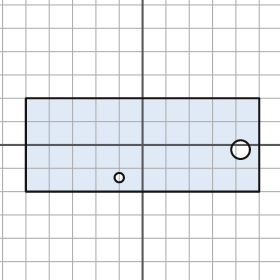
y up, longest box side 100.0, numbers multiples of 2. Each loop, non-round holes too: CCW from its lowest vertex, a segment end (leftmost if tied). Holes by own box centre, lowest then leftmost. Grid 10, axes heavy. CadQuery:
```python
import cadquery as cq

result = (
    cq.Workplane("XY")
    .moveTo(-50.0, -20.0)
    .lineTo(50.0, -20.0)
    .lineTo(50.0, 20.0)
    .lineTo(-50.0, 20.0)
    .close()
    .moveTo(-10.0, -14.0)
    .circle(2.0)
    .moveTo(42.0, -2.0)
    .circle(4.0)
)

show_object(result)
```